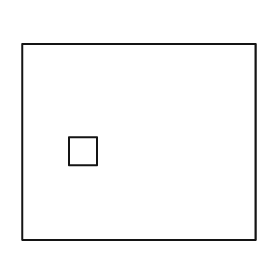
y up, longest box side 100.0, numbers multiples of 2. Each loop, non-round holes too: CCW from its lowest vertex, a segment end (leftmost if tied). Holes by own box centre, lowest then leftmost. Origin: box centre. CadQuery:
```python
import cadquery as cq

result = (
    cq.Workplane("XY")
    .moveTo(-50.0, -42.0)
    .lineTo(50.0, -42.0)
    .lineTo(50.0, 42.0)
    .lineTo(-50.0, 42.0)
    .close()
    .moveTo(-30.0, -10.0)
    .lineTo(-18.0, -10.0)
    .lineTo(-18.0, 2.0)
    .lineTo(-30.0, 2.0)
    .close()
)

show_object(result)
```